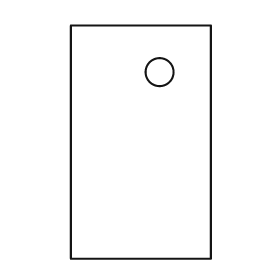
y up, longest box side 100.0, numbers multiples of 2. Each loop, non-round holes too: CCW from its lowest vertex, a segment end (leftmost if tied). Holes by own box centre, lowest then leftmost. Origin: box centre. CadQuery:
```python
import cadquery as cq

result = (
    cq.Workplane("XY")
    .moveTo(-30.0, -50.0)
    .lineTo(30.0, -50.0)
    .lineTo(30.0, 50.0)
    .lineTo(-30.0, 50.0)
    .close()
    .moveTo(8.0, 30.0)
    .circle(6.0)
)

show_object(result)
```